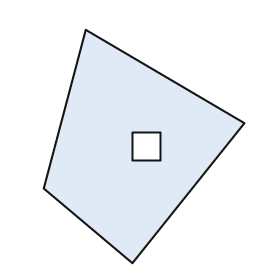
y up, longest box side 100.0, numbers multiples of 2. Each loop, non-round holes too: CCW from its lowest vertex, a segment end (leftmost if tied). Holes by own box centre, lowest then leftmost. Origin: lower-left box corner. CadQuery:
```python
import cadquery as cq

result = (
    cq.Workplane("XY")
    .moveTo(38.0, 0.0)
    .lineTo(86.0, 60.0)
    .lineTo(18.0, 100.0)
    .lineTo(0.0, 32.0)
    .close()
    .moveTo(38.0, 44.0)
    .lineTo(50.0, 44.0)
    .lineTo(50.0, 56.0)
    .lineTo(38.0, 56.0)
    .close()
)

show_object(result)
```